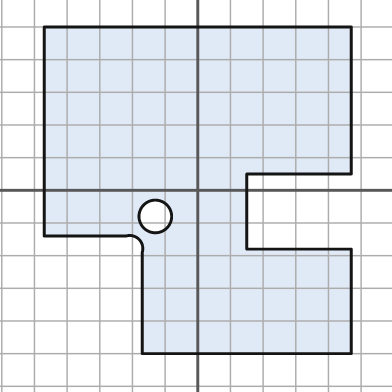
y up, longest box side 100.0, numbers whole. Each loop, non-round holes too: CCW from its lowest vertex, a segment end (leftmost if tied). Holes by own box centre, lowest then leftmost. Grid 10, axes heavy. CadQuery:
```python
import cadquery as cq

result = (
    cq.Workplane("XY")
    .moveTo(-17.0, -50.0)
    .lineTo(47.0, -50.0)
    .lineTo(47.0, -18.0)
    .lineTo(15.0, -18.0)
    .lineTo(15.0, 5.0)
    .lineTo(47.0, 5.0)
    .lineTo(47.0, 50.0)
    .lineTo(-47.0, 50.0)
    .lineTo(-47.0, -14.0)
    .lineTo(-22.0, -14.0)
    .threePointArc((-18.0, -15.0), (-17.0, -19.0))
    .close()
    .moveTo(-13.0, -8.0)
    .circle(5.0)
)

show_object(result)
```